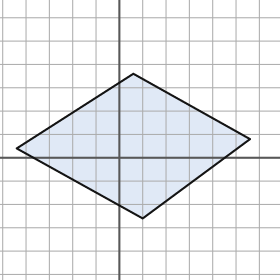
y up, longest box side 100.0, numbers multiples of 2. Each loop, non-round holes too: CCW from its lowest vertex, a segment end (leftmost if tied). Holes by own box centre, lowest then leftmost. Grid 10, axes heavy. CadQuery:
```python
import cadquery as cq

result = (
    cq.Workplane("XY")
    .moveTo(10.0, -26.0)
    .lineTo(56.0, 8.0)
    .lineTo(6.0, 36.0)
    .lineTo(-44.0, 4.0)
    .close()
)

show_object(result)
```